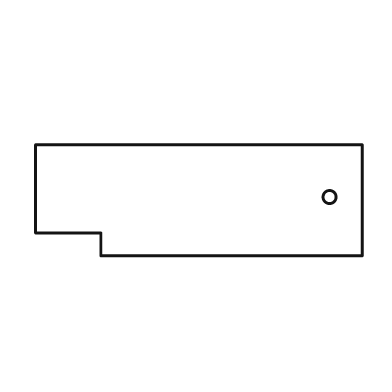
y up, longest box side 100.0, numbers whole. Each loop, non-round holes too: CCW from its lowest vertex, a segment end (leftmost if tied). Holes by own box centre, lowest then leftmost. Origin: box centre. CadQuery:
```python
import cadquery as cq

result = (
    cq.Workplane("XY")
    .moveTo(-30.0, -17.0)
    .lineTo(50.0, -17.0)
    .lineTo(50.0, 17.0)
    .lineTo(-50.0, 17.0)
    .lineTo(-50.0, -10.0)
    .lineTo(-30.0, -10.0)
    .close()
    .moveTo(40.0, 1.0)
    .circle(2.0)
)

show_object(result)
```